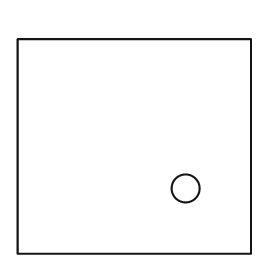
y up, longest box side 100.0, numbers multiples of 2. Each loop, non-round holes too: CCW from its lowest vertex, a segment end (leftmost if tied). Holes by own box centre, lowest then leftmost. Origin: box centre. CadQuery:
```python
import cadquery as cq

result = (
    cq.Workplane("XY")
    .moveTo(-50.0, -46.0)
    .lineTo(50.0, -46.0)
    .lineTo(50.0, 46.0)
    .lineTo(-50.0, 46.0)
    .close()
    .moveTo(22.0, -18.0)
    .circle(6.0)
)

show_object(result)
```